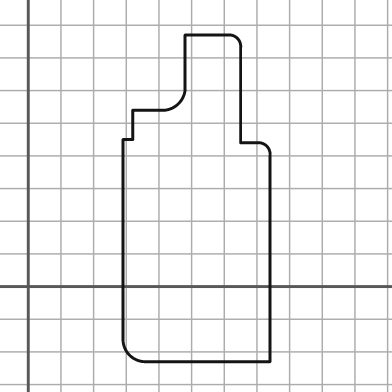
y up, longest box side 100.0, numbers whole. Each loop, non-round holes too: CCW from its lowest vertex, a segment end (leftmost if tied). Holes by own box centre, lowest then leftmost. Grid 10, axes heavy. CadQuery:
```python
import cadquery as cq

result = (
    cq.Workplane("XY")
    .moveTo(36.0, -23.0)
    .lineTo(74.0, -23.0)
    .lineTo(74.0, 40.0)
    .threePointArc((73.0, 43.0), (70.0, 44.0))
    .lineTo(65.0, 44.0)
    .lineTo(65.0, 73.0)
    .threePointArc((64.0, 76.0), (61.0, 77.0))
    .lineTo(48.0, 77.0)
    .lineTo(48.0, 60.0)
    .threePointArc((46.0, 56.0), (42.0, 54.0))
    .lineTo(32.0, 54.0)
    .lineTo(32.0, 45.0)
    .lineTo(29.0, 45.0)
    .lineTo(29.0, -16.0)
    .threePointArc((31.0, -21.0), (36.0, -23.0))
    .close()
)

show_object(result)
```